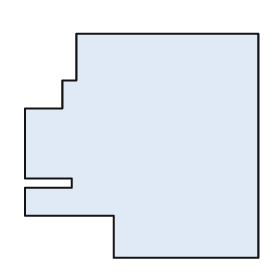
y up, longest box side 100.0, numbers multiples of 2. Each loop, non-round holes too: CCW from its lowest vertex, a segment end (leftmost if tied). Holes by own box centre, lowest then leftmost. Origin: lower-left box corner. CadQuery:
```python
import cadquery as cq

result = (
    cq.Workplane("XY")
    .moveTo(38.0, 0.0)
    .lineTo(100.0, 0.0)
    .lineTo(100.0, 96.0)
    .lineTo(22.0, 96.0)
    .lineTo(22.0, 76.0)
    .lineTo(16.0, 76.0)
    .lineTo(16.0, 64.0)
    .lineTo(0.0, 64.0)
    .lineTo(0.0, 34.0)
    .lineTo(20.0, 34.0)
    .lineTo(20.0, 30.0)
    .lineTo(0.0, 30.0)
    .lineTo(0.0, 18.0)
    .lineTo(38.0, 18.0)
    .close()
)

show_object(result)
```